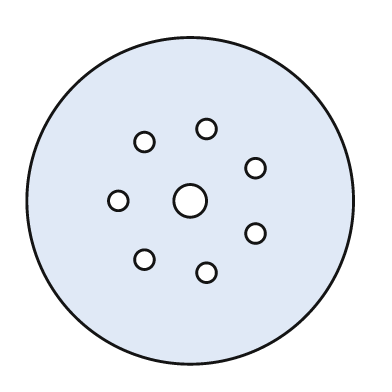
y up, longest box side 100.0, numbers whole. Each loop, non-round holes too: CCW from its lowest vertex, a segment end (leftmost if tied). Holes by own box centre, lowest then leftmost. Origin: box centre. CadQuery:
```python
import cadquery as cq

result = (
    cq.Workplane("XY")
    .moveTo(0.0, 0.0)
    .circle(50.0)
    .moveTo(5.0, -22.0)
    .circle(3.0)
    .moveTo(-14.0, -18.0)
    .circle(3.0)
    .moveTo(20.0, -10.0)
    .circle(3.0)
    .moveTo(-22.0, 0.0)
    .circle(3.0)
    .moveTo(0.0, 0.0)
    .circle(5.0)
    .moveTo(20.0, 10.0)
    .circle(3.0)
    .moveTo(-14.0, 18.0)
    .circle(3.0)
    .moveTo(5.0, 22.0)
    .circle(3.0)
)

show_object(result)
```